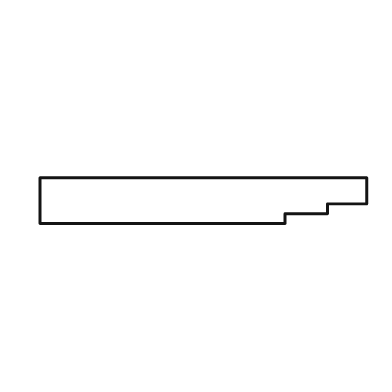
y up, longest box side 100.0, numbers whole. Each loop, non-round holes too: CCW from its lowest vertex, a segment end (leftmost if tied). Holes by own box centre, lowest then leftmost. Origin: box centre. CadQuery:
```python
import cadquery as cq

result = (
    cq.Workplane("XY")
    .moveTo(-50.0, -7.0)
    .lineTo(25.0, -7.0)
    .lineTo(25.0, -4.0)
    .lineTo(38.0, -4.0)
    .lineTo(38.0, -1.0)
    .lineTo(50.0, -1.0)
    .lineTo(50.0, 7.0)
    .lineTo(-50.0, 7.0)
    .close()
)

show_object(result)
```